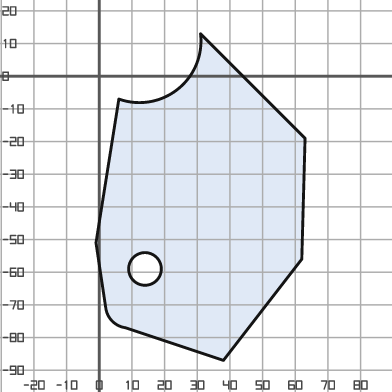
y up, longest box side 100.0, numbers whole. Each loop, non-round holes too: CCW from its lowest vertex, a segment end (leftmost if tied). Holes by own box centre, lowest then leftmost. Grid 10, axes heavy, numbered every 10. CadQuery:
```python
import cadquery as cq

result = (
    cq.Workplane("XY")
    .moveTo(38.0, -87.0)
    .lineTo(62.0, -56.0)
    .lineTo(63.0, -19.0)
    .lineTo(31.0, 13.0)
    .threePointArc((24.0, -4.0), (6.0, -7.0))
    .lineTo(-1.0, -51.0)
    .lineTo(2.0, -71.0)
    .threePointArc((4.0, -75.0), (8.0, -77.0))
    .close()
    .moveTo(14.0, -59.0)
    .circle(5.0)
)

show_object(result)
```